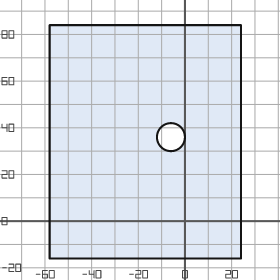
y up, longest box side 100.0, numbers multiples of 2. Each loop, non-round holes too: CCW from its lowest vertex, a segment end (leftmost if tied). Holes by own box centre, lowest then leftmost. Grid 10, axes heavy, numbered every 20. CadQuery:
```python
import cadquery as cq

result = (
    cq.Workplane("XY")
    .moveTo(-58.0, -16.0)
    .lineTo(24.0, -16.0)
    .lineTo(24.0, 84.0)
    .lineTo(-58.0, 84.0)
    .close()
    .moveTo(-6.0, 36.0)
    .circle(6.0)
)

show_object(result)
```